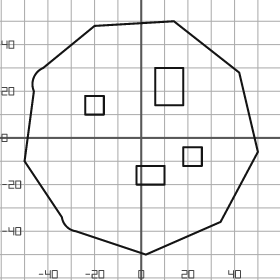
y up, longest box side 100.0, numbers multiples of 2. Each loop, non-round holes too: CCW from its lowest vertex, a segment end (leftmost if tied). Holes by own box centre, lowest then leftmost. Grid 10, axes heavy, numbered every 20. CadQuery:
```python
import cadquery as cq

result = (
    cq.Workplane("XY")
    .moveTo(2.0, -50.0)
    .lineTo(34.0, -36.0)
    .lineTo(50.0, -6.0)
    .lineTo(42.0, 28.0)
    .lineTo(14.0, 50.0)
    .lineTo(-20.0, 48.0)
    .lineTo(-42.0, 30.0)
    .threePointArc((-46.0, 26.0), (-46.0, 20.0))
    .lineTo(-50.0, -10.0)
    .lineTo(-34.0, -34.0)
    .threePointArc((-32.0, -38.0), (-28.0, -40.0))
    .close()
    .moveTo(-2.0, -20.0)
    .lineTo(10.0, -20.0)
    .lineTo(10.0, -12.0)
    .lineTo(-2.0, -12.0)
    .close()
    .moveTo(18.0, -12.0)
    .lineTo(26.0, -12.0)
    .lineTo(26.0, -4.0)
    .lineTo(18.0, -4.0)
    .close()
    .moveTo(-24.0, 10.0)
    .lineTo(-16.0, 10.0)
    .lineTo(-16.0, 18.0)
    .lineTo(-24.0, 18.0)
    .close()
    .moveTo(6.0, 14.0)
    .lineTo(18.0, 14.0)
    .lineTo(18.0, 30.0)
    .lineTo(6.0, 30.0)
    .close()
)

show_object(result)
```